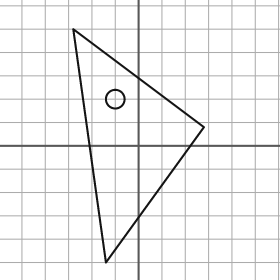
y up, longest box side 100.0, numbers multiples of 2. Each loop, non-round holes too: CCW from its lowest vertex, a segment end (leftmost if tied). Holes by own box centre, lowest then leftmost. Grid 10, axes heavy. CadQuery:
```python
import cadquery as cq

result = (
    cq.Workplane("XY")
    .moveTo(-14.0, -50.0)
    .lineTo(28.0, 8.0)
    .lineTo(-28.0, 50.0)
    .close()
    .moveTo(-10.0, 20.0)
    .circle(4.0)
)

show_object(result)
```